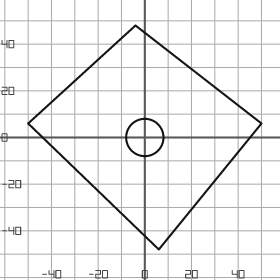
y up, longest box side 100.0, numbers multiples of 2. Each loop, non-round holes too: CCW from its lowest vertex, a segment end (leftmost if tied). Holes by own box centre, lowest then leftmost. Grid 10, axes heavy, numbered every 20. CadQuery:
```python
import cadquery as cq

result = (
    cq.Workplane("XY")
    .moveTo(6.0, -48.0)
    .lineTo(50.0, 6.0)
    .lineTo(-4.0, 48.0)
    .lineTo(-50.0, 6.0)
    .close()
    .moveTo(0.0, 0.0)
    .circle(8.0)
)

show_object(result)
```